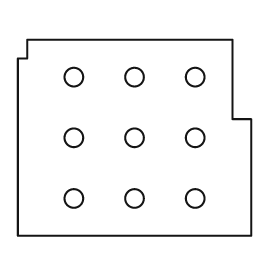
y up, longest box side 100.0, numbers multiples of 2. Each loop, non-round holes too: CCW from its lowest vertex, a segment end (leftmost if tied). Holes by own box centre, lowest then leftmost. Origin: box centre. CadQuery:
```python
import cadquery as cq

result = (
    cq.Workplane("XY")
    .moveTo(-50.0, -42.0)
    .lineTo(50.0, -42.0)
    .lineTo(50.0, 8.0)
    .lineTo(42.0, 8.0)
    .lineTo(42.0, 42.0)
    .lineTo(-46.0, 42.0)
    .lineTo(-46.0, 34.0)
    .lineTo(-50.0, 34.0)
    .close()
    .moveTo(-26.0, -26.0)
    .circle(4.0)
    .moveTo(0.0, -26.0)
    .circle(4.0)
    .moveTo(26.0, -26.0)
    .circle(4.0)
    .moveTo(-26.0, 0.0)
    .circle(4.0)
    .moveTo(0.0, 0.0)
    .circle(4.0)
    .moveTo(26.0, 0.0)
    .circle(4.0)
    .moveTo(-26.0, 26.0)
    .circle(4.0)
    .moveTo(0.0, 26.0)
    .circle(4.0)
    .moveTo(26.0, 26.0)
    .circle(4.0)
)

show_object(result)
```